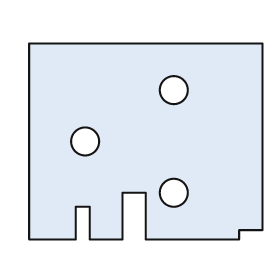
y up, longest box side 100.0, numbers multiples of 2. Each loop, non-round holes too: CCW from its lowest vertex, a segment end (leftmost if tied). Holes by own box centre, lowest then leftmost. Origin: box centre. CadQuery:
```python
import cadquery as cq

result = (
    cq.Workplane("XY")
    .moveTo(-50.0, -42.0)
    .lineTo(-30.0, -42.0)
    .lineTo(-30.0, -28.0)
    .lineTo(-24.0, -28.0)
    .lineTo(-24.0, -42.0)
    .lineTo(-10.0, -42.0)
    .lineTo(-10.0, -22.0)
    .lineTo(0.0, -22.0)
    .lineTo(0.0, -42.0)
    .lineTo(40.0, -42.0)
    .lineTo(40.0, -38.0)
    .lineTo(50.0, -38.0)
    .lineTo(50.0, 42.0)
    .lineTo(-50.0, 42.0)
    .close()
    .moveTo(12.0, -22.0)
    .circle(6.0)
    .moveTo(-26.0, 0.0)
    .circle(6.0)
    .moveTo(12.0, 22.0)
    .circle(6.0)
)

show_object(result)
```